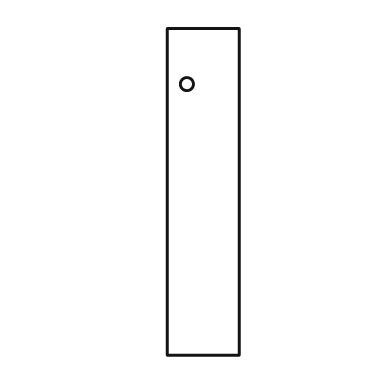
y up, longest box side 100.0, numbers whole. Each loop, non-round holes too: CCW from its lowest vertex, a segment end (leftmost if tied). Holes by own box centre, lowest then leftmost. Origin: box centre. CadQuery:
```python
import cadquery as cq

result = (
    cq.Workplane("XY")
    .moveTo(-11.0, -50.0)
    .lineTo(11.0, -50.0)
    .lineTo(11.0, 50.0)
    .lineTo(-11.0, 50.0)
    .close()
    .moveTo(-5.0, 33.0)
    .circle(2.0)
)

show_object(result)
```